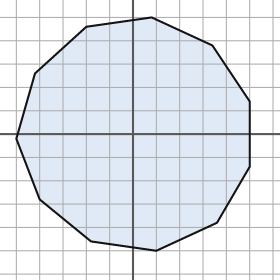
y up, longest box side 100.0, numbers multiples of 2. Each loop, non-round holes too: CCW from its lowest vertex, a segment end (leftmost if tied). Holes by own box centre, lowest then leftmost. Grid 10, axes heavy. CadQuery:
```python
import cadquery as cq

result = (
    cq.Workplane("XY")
    .moveTo(10.0, -50.0)
    .lineTo(36.0, -38.0)
    .lineTo(50.0, -14.0)
    .lineTo(50.0, 14.0)
    .lineTo(34.0, 38.0)
    .lineTo(8.0, 50.0)
    .lineTo(-20.0, 46.0)
    .lineTo(-42.0, 26.0)
    .lineTo(-50.0, -2.0)
    .lineTo(-40.0, -28.0)
    .lineTo(-18.0, -46.0)
    .close()
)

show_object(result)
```